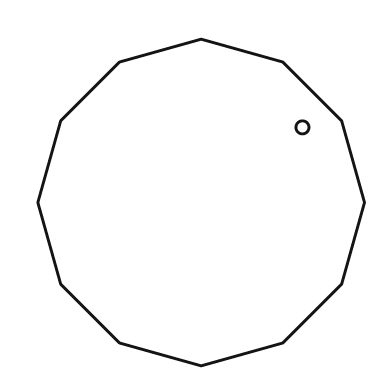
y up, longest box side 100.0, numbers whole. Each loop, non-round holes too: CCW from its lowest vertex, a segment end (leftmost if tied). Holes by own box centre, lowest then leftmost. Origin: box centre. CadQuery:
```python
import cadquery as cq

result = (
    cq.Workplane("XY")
    .moveTo(0.0, -50.0)
    .lineTo(25.0, -43.0)
    .lineTo(43.0, -25.0)
    .lineTo(50.0, 0.0)
    .lineTo(43.0, 25.0)
    .lineTo(25.0, 43.0)
    .lineTo(0.0, 50.0)
    .lineTo(-25.0, 43.0)
    .lineTo(-43.0, 25.0)
    .lineTo(-50.0, 0.0)
    .lineTo(-43.0, -25.0)
    .lineTo(-25.0, -43.0)
    .close()
    .moveTo(31.0, 23.0)
    .circle(2.0)
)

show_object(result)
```